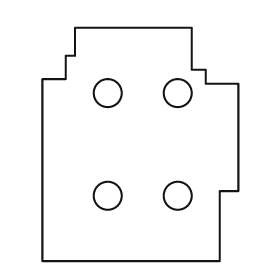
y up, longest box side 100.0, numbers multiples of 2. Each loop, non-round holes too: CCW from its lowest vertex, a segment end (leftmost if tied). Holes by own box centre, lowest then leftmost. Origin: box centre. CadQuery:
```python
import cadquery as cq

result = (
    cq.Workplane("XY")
    .moveTo(-42.0, -50.0)
    .lineTo(34.0, -50.0)
    .lineTo(34.0, -20.0)
    .lineTo(42.0, -20.0)
    .lineTo(42.0, 26.0)
    .lineTo(28.0, 26.0)
    .lineTo(28.0, 32.0)
    .lineTo(22.0, 32.0)
    .lineTo(22.0, 50.0)
    .lineTo(-28.0, 50.0)
    .lineTo(-28.0, 38.0)
    .lineTo(-32.0, 38.0)
    .lineTo(-32.0, 28.0)
    .lineTo(-42.0, 28.0)
    .close()
    .moveTo(-14.0, -22.0)
    .circle(6.0)
    .moveTo(16.0, -22.0)
    .circle(6.0)
    .moveTo(-14.0, 22.0)
    .circle(6.0)
    .moveTo(16.0, 22.0)
    .circle(6.0)
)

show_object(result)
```